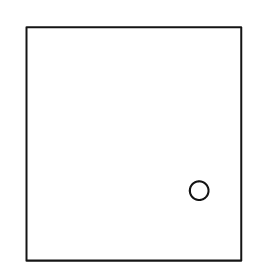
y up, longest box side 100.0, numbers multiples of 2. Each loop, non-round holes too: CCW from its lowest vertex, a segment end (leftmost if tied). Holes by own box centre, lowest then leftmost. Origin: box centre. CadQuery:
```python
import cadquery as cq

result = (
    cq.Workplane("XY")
    .moveTo(-46.0, -50.0)
    .lineTo(46.0, -50.0)
    .lineTo(46.0, 50.0)
    .lineTo(-46.0, 50.0)
    .close()
    .moveTo(28.0, -20.0)
    .circle(4.0)
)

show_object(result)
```